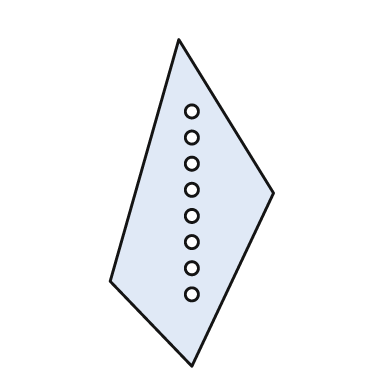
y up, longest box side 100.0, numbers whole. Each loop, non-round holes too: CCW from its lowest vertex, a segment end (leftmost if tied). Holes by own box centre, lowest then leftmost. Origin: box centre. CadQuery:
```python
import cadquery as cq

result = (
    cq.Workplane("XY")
    .moveTo(0.0, -50.0)
    .lineTo(25.0, 3.0)
    .lineTo(-4.0, 50.0)
    .lineTo(-25.0, -24.0)
    .close()
    .moveTo(0.0, -28.0)
    .circle(2.0)
    .moveTo(0.0, -20.0)
    .circle(2.0)
    .moveTo(0.0, -12.0)
    .circle(2.0)
    .moveTo(0.0, -4.0)
    .circle(2.0)
    .moveTo(0.0, 4.0)
    .circle(2.0)
    .moveTo(0.0, 12.0)
    .circle(2.0)
    .moveTo(0.0, 20.0)
    .circle(2.0)
    .moveTo(0.0, 28.0)
    .circle(2.0)
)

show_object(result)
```